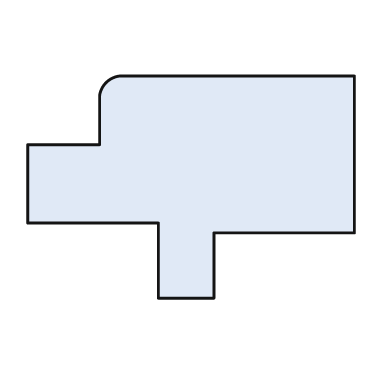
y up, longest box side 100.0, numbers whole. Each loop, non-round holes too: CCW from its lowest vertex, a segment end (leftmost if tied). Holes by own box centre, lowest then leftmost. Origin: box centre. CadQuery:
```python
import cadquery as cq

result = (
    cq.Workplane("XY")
    .moveTo(-10.0, -34.0)
    .lineTo(7.0, -34.0)
    .lineTo(7.0, -14.0)
    .lineTo(50.0, -14.0)
    .lineTo(50.0, 34.0)
    .lineTo(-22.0, 34.0)
    .threePointArc((-26.0, 32.0), (-28.0, 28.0))
    .lineTo(-28.0, 13.0)
    .lineTo(-50.0, 13.0)
    .lineTo(-50.0, -11.0)
    .lineTo(-10.0, -11.0)
    .close()
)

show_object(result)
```